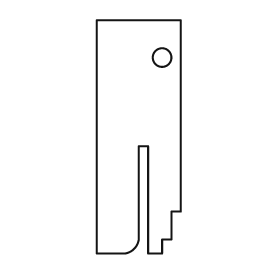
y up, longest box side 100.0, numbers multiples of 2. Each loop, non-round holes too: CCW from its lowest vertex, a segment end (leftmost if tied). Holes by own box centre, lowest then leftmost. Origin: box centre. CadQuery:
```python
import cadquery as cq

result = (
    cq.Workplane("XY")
    .moveTo(-18.0, -50.0)
    .lineTo(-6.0, -50.0)
    .threePointArc((-2.0, -48.0), (0.0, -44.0))
    .lineTo(0.0, -4.0)
    .lineTo(4.0, -4.0)
    .lineTo(4.0, -50.0)
    .lineTo(10.0, -50.0)
    .lineTo(10.0, -44.0)
    .lineTo(14.0, -44.0)
    .lineTo(14.0, -32.0)
    .lineTo(18.0, -32.0)
    .lineTo(18.0, 50.0)
    .lineTo(-18.0, 50.0)
    .close()
    .moveTo(10.0, 34.0)
    .circle(4.0)
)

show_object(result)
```